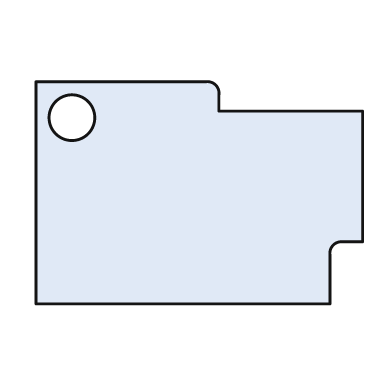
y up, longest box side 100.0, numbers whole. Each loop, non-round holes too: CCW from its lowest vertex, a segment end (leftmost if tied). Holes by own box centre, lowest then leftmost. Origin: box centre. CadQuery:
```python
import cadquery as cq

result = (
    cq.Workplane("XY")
    .moveTo(-50.0, -34.0)
    .lineTo(40.0, -34.0)
    .lineTo(40.0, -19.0)
    .threePointArc((41.0, -16.0), (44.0, -15.0))
    .lineTo(50.0, -15.0)
    .lineTo(50.0, 25.0)
    .lineTo(6.0, 25.0)
    .lineTo(6.0, 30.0)
    .threePointArc((5.0, 33.0), (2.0, 34.0))
    .lineTo(-50.0, 34.0)
    .close()
    .moveTo(-39.0, 23.0)
    .circle(7.0)
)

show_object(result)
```